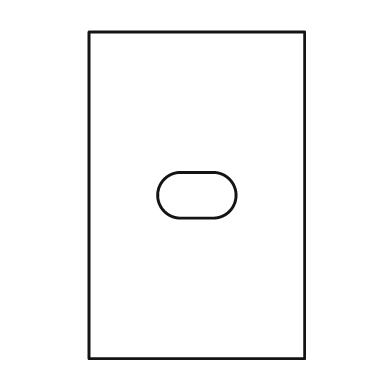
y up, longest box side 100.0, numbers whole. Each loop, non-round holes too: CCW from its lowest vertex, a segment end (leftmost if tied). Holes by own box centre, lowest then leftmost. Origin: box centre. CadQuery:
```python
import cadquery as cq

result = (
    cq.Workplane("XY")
    .moveTo(-33.0, -50.0)
    .lineTo(33.0, -50.0)
    .lineTo(33.0, 50.0)
    .lineTo(-33.0, 50.0)
    .close()
    .moveTo(-5.0, -7.0)
    .lineTo(5.0, -7.0)
    .threePointArc((12.0, 0.0), (5.0, 7.0))
    .lineTo(-5.0, 7.0)
    .threePointArc((-12.0, 0.0), (-5.0, -7.0))
    .close()
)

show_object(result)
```